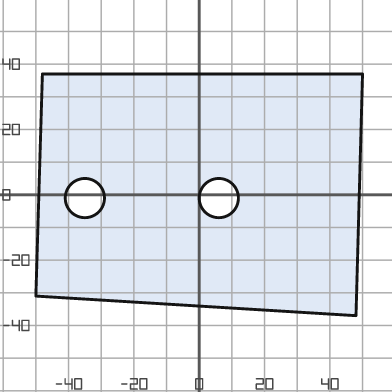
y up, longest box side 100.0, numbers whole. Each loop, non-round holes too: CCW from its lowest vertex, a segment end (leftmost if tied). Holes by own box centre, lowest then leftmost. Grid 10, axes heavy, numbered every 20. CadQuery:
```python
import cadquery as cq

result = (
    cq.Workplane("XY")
    .moveTo(48.0, -37.0)
    .lineTo(50.0, 37.0)
    .lineTo(-48.0, 37.0)
    .lineTo(-50.0, -31.0)
    .close()
    .moveTo(-35.0, -1.0)
    .circle(6.0)
    .moveTo(6.0, -1.0)
    .circle(6.0)
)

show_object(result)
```